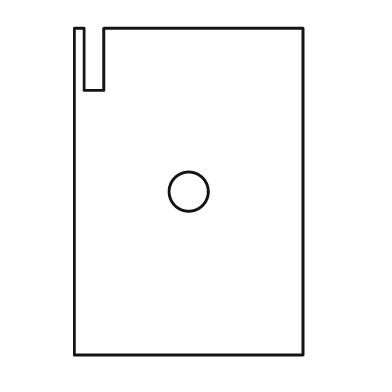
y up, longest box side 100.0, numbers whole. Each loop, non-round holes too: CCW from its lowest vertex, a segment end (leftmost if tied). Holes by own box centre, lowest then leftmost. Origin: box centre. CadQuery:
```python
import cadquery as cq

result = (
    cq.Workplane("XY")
    .moveTo(-35.0, -50.0)
    .lineTo(35.0, -50.0)
    .lineTo(35.0, 50.0)
    .lineTo(-26.0, 50.0)
    .lineTo(-26.0, 31.0)
    .lineTo(-32.0, 31.0)
    .lineTo(-32.0, 50.0)
    .lineTo(-35.0, 50.0)
    .close()
    .moveTo(0.0, 0.0)
    .circle(6.0)
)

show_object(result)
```